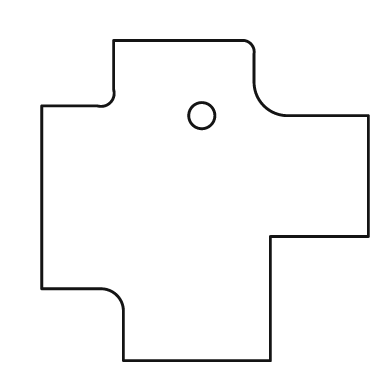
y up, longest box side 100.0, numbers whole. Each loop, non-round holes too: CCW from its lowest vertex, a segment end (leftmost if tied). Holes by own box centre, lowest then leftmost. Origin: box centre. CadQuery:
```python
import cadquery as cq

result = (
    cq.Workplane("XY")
    .moveTo(-25.0, -49.0)
    .lineTo(20.0, -49.0)
    .lineTo(20.0, -11.0)
    .lineTo(50.0, -11.0)
    .lineTo(50.0, 26.0)
    .lineTo(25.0, 26.0)
    .threePointArc((18.0, 29.0), (15.0, 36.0))
    .lineTo(15.0, 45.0)
    .threePointArc((14.0, 48.0), (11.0, 49.0))
    .lineTo(-28.0, 49.0)
    .lineTo(-28.0, 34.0)
    .threePointArc((-29.0, 30.0), (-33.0, 29.0))
    .lineTo(-50.0, 29.0)
    .lineTo(-50.0, -27.0)
    .lineTo(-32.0, -27.0)
    .threePointArc((-27.0, -29.0), (-25.0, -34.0))
    .close()
    .moveTo(-1.0, 26.0)
    .circle(4.0)
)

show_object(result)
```